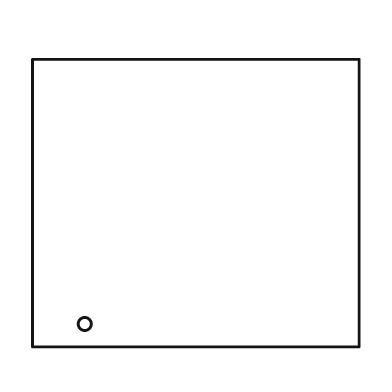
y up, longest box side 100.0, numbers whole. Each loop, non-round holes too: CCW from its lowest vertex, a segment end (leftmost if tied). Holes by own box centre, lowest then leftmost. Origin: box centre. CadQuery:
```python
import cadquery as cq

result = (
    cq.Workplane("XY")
    .moveTo(-50.0, -44.0)
    .lineTo(50.0, -44.0)
    .lineTo(50.0, 44.0)
    .lineTo(-50.0, 44.0)
    .close()
    .moveTo(-34.0, -37.0)
    .circle(2.0)
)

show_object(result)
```